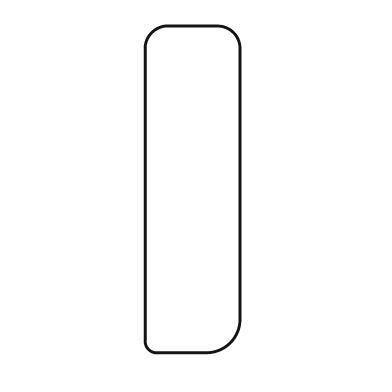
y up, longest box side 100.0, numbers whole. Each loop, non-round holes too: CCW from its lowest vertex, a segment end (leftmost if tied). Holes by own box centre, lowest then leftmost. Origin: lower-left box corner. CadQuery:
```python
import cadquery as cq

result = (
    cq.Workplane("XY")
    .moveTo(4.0, 0.0)
    .lineTo(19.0, 0.0)
    .threePointArc((26.0, 3.0), (29.0, 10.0))
    .lineTo(29.0, 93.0)
    .threePointArc((27.0, 98.0), (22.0, 100.0))
    .lineTo(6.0, 100.0)
    .threePointArc((2.0, 98.0), (0.0, 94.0))
    .lineTo(0.0, 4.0)
    .threePointArc((1.0, 1.0), (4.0, 0.0))
    .close()
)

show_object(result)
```